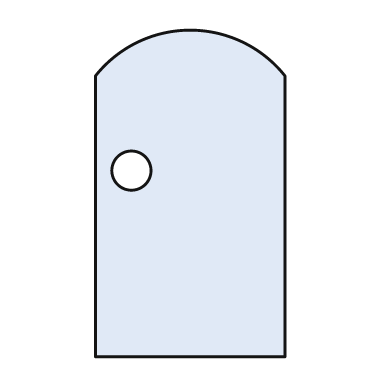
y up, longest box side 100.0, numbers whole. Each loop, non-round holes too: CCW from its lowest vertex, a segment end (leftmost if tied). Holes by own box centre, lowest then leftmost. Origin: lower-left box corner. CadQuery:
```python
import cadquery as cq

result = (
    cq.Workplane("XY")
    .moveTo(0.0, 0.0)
    .lineTo(58.0, 0.0)
    .lineTo(58.0, 86.0)
    .threePointArc((29.0, 100.0), (0.0, 86.0))
    .close()
    .moveTo(11.0, 57.0)
    .circle(6.0)
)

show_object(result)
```